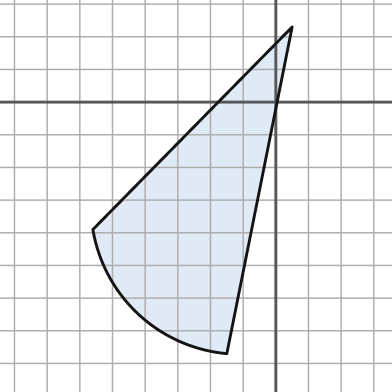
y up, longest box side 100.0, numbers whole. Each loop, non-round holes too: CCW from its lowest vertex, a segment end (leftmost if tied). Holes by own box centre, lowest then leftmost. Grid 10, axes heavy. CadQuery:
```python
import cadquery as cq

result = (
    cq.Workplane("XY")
    .moveTo(-15.0, -77.0)
    .lineTo(5.0, 23.0)
    .lineTo(-56.0, -39.0)
    .threePointArc((-42.0, -65.0), (-15.0, -77.0))
    .close()
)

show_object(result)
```